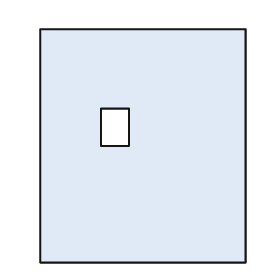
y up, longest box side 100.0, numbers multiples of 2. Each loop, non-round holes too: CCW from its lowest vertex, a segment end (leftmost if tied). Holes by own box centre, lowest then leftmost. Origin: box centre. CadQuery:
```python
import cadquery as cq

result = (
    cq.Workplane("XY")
    .moveTo(-44.0, -50.0)
    .lineTo(44.0, -50.0)
    .lineTo(44.0, 50.0)
    .lineTo(-44.0, 50.0)
    .close()
    .moveTo(-18.0, 0.0)
    .lineTo(-6.0, 0.0)
    .lineTo(-6.0, 16.0)
    .lineTo(-18.0, 16.0)
    .close()
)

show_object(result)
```